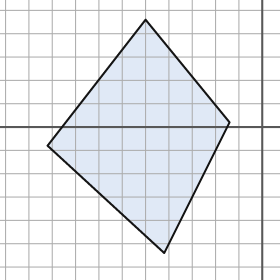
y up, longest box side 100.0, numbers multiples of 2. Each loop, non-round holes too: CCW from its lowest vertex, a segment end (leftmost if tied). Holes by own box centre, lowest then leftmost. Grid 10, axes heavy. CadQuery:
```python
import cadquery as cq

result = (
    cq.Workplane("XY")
    .moveTo(-42.0, -54.0)
    .lineTo(-14.0, 2.0)
    .lineTo(-50.0, 46.0)
    .lineTo(-92.0, -8.0)
    .close()
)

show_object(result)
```